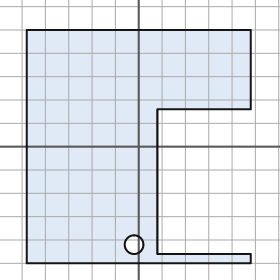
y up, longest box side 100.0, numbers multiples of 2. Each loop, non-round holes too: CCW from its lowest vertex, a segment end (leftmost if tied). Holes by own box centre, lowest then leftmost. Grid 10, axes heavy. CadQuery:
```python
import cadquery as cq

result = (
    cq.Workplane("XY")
    .moveTo(-48.0, -50.0)
    .lineTo(48.0, -50.0)
    .lineTo(48.0, -46.0)
    .lineTo(8.0, -46.0)
    .lineTo(8.0, 16.0)
    .lineTo(48.0, 16.0)
    .lineTo(48.0, 50.0)
    .lineTo(-48.0, 50.0)
    .close()
    .moveTo(-2.0, -42.0)
    .circle(4.0)
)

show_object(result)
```